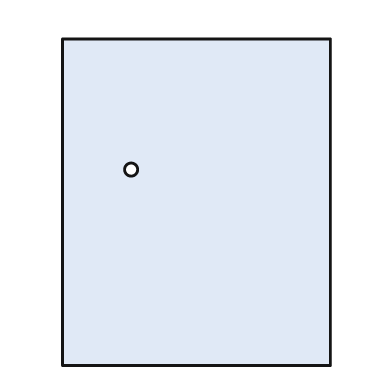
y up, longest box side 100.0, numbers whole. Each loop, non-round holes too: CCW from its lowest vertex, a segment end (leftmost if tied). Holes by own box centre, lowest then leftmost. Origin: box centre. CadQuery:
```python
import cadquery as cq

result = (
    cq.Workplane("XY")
    .moveTo(-41.0, -50.0)
    .lineTo(41.0, -50.0)
    .lineTo(41.0, 50.0)
    .lineTo(-41.0, 50.0)
    .close()
    .moveTo(-20.0, 10.0)
    .circle(2.0)
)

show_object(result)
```